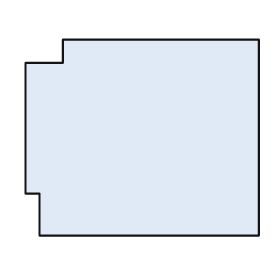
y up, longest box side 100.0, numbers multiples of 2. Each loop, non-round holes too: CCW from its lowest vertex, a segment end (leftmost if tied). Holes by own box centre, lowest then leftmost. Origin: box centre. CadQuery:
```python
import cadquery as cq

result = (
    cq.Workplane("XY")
    .moveTo(-44.0, -42.0)
    .lineTo(50.0, -42.0)
    .lineTo(50.0, 42.0)
    .lineTo(-34.0, 42.0)
    .lineTo(-34.0, 32.0)
    .lineTo(-50.0, 32.0)
    .lineTo(-50.0, -24.0)
    .lineTo(-44.0, -24.0)
    .close()
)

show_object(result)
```